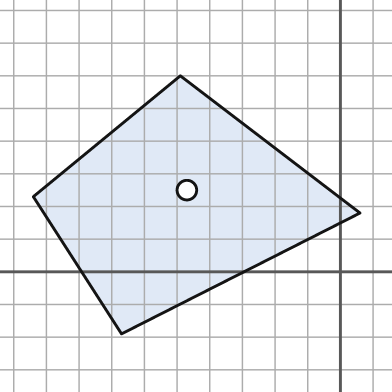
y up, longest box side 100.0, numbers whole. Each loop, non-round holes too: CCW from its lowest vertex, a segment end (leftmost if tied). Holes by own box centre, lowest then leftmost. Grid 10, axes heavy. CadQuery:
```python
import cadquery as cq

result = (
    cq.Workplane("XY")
    .moveTo(-67.0, -19.0)
    .lineTo(6.0, 18.0)
    .lineTo(-49.0, 60.0)
    .lineTo(-94.0, 23.0)
    .close()
    .moveTo(-47.0, 25.0)
    .circle(3.0)
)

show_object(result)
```